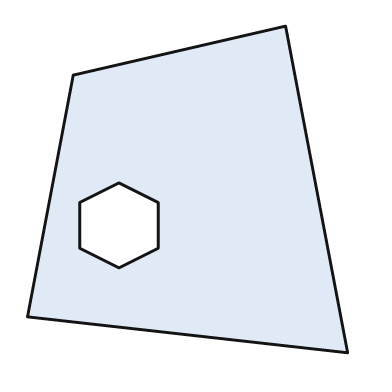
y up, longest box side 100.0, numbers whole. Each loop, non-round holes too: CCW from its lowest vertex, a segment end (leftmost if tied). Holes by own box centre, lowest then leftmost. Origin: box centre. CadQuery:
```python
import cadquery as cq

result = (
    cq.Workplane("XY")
    .moveTo(49.0, -50.0)
    .lineTo(30.0, 50.0)
    .lineTo(-35.0, 35.0)
    .lineTo(-49.0, -39.0)
    .close()
    .moveTo(-21.0, -24.0)
    .lineTo(-9.0, -18.0)
    .lineTo(-9.0, -4.0)
    .lineTo(-21.0, 2.0)
    .lineTo(-33.0, -4.0)
    .lineTo(-33.0, -18.0)
    .close()
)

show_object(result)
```